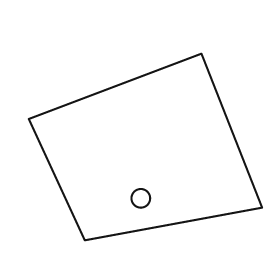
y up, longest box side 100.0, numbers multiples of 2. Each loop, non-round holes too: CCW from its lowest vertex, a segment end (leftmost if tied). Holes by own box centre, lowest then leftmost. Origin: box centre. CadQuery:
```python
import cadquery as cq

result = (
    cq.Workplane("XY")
    .moveTo(-26.0, -40.0)
    .lineTo(50.0, -26.0)
    .lineTo(24.0, 40.0)
    .lineTo(-50.0, 12.0)
    .close()
    .moveTo(-2.0, -22.0)
    .circle(4.0)
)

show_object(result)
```